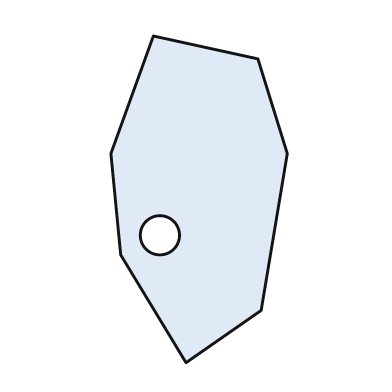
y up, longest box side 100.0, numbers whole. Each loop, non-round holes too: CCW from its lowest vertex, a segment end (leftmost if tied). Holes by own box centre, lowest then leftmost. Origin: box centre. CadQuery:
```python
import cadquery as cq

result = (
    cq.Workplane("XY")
    .moveTo(-4.0, -50.0)
    .lineTo(19.0, -34.0)
    .lineTo(27.0, 14.0)
    .lineTo(18.0, 43.0)
    .lineTo(-14.0, 50.0)
    .lineTo(-27.0, 14.0)
    .lineTo(-24.0, -17.0)
    .close()
    .moveTo(-12.0, -11.0)
    .circle(6.0)
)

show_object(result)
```